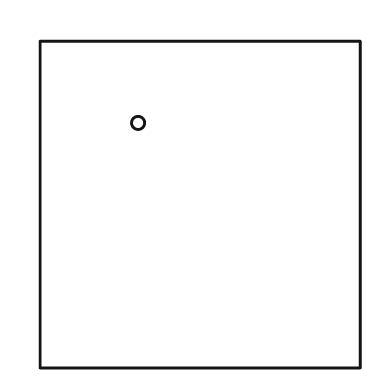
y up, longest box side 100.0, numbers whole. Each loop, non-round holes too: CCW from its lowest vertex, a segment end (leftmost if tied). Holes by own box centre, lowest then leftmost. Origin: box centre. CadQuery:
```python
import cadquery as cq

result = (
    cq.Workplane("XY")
    .moveTo(-49.0, -50.0)
    .lineTo(49.0, -50.0)
    .lineTo(49.0, 50.0)
    .lineTo(-49.0, 50.0)
    .close()
    .moveTo(-19.0, 25.0)
    .circle(2.0)
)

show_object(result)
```